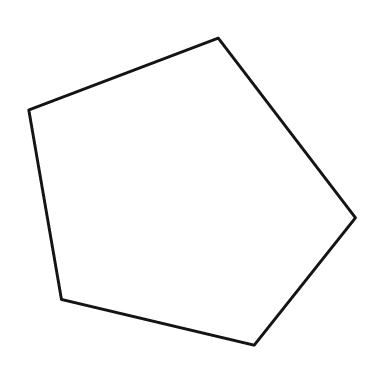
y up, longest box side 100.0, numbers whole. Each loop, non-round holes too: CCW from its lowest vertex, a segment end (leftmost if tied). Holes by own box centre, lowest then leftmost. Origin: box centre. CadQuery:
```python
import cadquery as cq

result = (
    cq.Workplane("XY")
    .moveTo(19.0, -47.0)
    .lineTo(50.0, -8.0)
    .lineTo(8.0, 47.0)
    .lineTo(-50.0, 25.0)
    .lineTo(-40.0, -33.0)
    .close()
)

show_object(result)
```